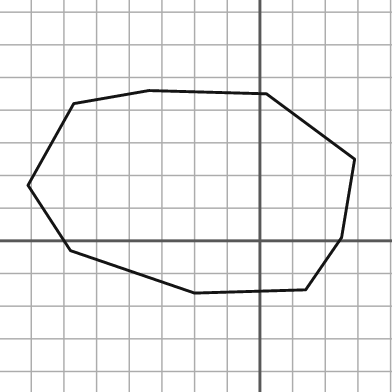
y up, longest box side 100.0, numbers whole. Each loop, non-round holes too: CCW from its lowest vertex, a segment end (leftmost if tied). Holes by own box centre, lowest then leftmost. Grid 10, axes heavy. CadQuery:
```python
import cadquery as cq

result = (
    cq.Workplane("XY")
    .moveTo(-20.0, -16.0)
    .lineTo(14.0, -15.0)
    .lineTo(25.0, 1.0)
    .lineTo(29.0, 25.0)
    .lineTo(2.0, 45.0)
    .lineTo(-34.0, 46.0)
    .lineTo(-57.0, 42.0)
    .lineTo(-71.0, 17.0)
    .lineTo(-58.0, -3.0)
    .close()
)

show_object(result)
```